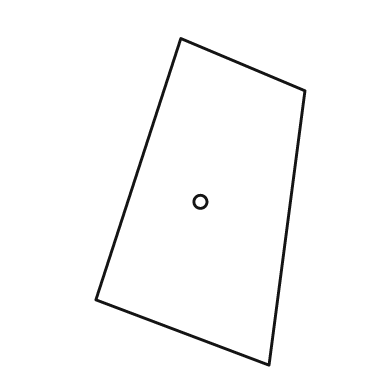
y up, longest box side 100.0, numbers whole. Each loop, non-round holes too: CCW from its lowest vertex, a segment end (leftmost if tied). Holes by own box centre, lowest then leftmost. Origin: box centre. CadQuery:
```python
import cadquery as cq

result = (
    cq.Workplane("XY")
    .moveTo(21.0, -50.0)
    .lineTo(32.0, 34.0)
    .lineTo(-6.0, 50.0)
    .lineTo(-32.0, -30.0)
    .close()
    .moveTo(0.0, 0.0)
    .circle(2.0)
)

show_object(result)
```